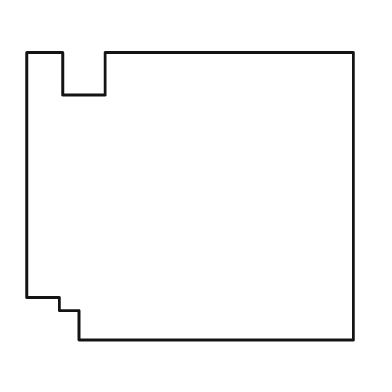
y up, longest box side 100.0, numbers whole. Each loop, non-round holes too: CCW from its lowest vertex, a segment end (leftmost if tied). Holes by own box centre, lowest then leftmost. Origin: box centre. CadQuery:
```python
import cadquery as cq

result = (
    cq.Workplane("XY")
    .moveTo(-34.0, -44.0)
    .lineTo(50.0, -44.0)
    .lineTo(50.0, 44.0)
    .lineTo(-26.0, 44.0)
    .lineTo(-26.0, 31.0)
    .lineTo(-39.0, 31.0)
    .lineTo(-39.0, 44.0)
    .lineTo(-50.0, 44.0)
    .lineTo(-50.0, -31.0)
    .lineTo(-40.0, -31.0)
    .lineTo(-40.0, -35.0)
    .lineTo(-34.0, -35.0)
    .close()
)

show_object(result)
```